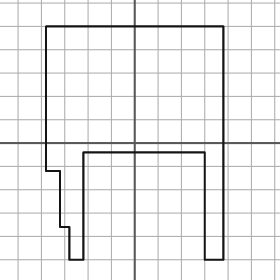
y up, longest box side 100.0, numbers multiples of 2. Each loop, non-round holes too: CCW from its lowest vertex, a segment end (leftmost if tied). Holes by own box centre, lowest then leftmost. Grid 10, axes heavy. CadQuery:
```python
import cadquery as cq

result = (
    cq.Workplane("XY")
    .moveTo(-28.0, -50.0)
    .lineTo(-22.0, -50.0)
    .lineTo(-22.0, -4.0)
    .lineTo(30.0, -4.0)
    .lineTo(30.0, -50.0)
    .lineTo(38.0, -50.0)
    .lineTo(38.0, 50.0)
    .lineTo(-38.0, 50.0)
    .lineTo(-38.0, -12.0)
    .lineTo(-32.0, -12.0)
    .lineTo(-32.0, -36.0)
    .lineTo(-28.0, -36.0)
    .close()
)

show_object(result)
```